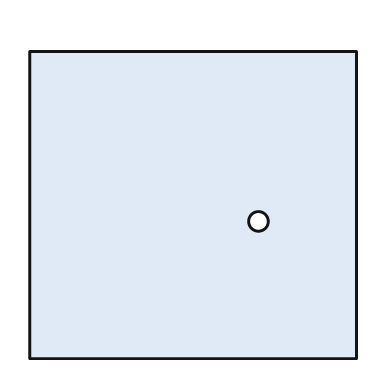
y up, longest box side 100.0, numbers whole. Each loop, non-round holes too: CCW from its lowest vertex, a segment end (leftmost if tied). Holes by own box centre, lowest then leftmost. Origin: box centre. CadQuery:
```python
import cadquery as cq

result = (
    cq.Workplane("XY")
    .moveTo(-50.0, -47.0)
    .lineTo(50.0, -47.0)
    .lineTo(50.0, 47.0)
    .lineTo(-50.0, 47.0)
    .close()
    .moveTo(20.0, -5.0)
    .circle(3.0)
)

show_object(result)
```